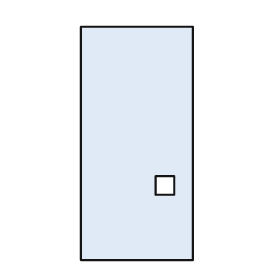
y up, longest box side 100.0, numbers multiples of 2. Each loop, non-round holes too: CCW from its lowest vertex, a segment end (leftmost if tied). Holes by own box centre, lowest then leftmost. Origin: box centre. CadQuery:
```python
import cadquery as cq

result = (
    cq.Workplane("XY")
    .moveTo(-24.0, -50.0)
    .lineTo(24.0, -50.0)
    .lineTo(24.0, 50.0)
    .lineTo(-24.0, 50.0)
    .close()
    .moveTo(8.0, -22.0)
    .lineTo(16.0, -22.0)
    .lineTo(16.0, -14.0)
    .lineTo(8.0, -14.0)
    .close()
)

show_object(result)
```